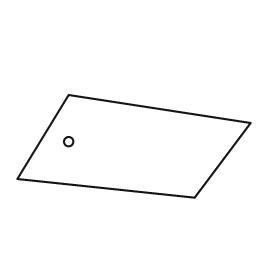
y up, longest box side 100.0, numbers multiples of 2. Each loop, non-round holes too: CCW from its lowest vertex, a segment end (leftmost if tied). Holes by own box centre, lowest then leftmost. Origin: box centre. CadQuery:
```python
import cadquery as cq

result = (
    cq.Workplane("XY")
    .moveTo(26.0, -22.0)
    .lineTo(50.0, 10.0)
    .lineTo(-28.0, 22.0)
    .lineTo(-50.0, -14.0)
    .close()
    .moveTo(-28.0, 2.0)
    .circle(2.0)
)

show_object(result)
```